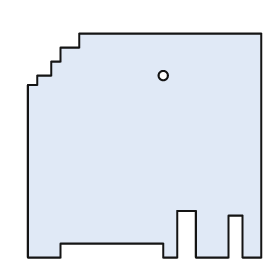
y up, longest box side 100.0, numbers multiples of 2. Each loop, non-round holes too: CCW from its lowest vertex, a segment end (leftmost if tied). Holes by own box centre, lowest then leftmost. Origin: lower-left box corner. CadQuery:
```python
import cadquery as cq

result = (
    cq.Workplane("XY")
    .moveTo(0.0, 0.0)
    .lineTo(14.0, 0.0)
    .lineTo(14.0, 6.0)
    .lineTo(58.0, 6.0)
    .lineTo(58.0, 0.0)
    .lineTo(64.0, 0.0)
    .lineTo(64.0, 20.0)
    .lineTo(72.0, 20.0)
    .lineTo(72.0, 0.0)
    .lineTo(86.0, 0.0)
    .lineTo(86.0, 18.0)
    .lineTo(92.0, 18.0)
    .lineTo(92.0, 0.0)
    .lineTo(100.0, 0.0)
    .lineTo(100.0, 96.0)
    .lineTo(22.0, 96.0)
    .lineTo(22.0, 90.0)
    .lineTo(14.0, 90.0)
    .lineTo(14.0, 84.0)
    .lineTo(10.0, 84.0)
    .lineTo(10.0, 78.0)
    .lineTo(4.0, 78.0)
    .lineTo(4.0, 74.0)
    .lineTo(0.0, 74.0)
    .close()
    .moveTo(58.0, 78.0)
    .circle(2.0)
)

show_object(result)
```